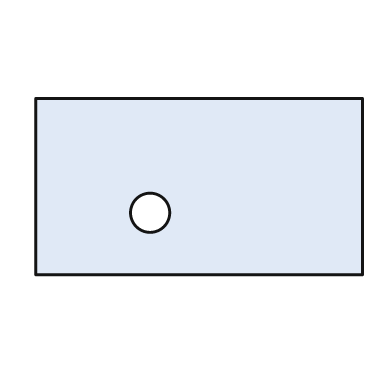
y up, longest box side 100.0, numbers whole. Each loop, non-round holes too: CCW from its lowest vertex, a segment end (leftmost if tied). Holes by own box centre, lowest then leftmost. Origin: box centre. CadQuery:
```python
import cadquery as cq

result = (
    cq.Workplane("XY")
    .moveTo(-50.0, -27.0)
    .lineTo(50.0, -27.0)
    .lineTo(50.0, 27.0)
    .lineTo(-50.0, 27.0)
    .close()
    .moveTo(-15.0, -8.0)
    .circle(6.0)
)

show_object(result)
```